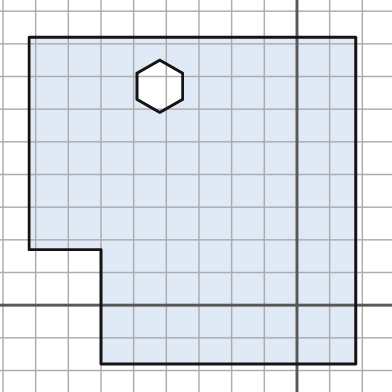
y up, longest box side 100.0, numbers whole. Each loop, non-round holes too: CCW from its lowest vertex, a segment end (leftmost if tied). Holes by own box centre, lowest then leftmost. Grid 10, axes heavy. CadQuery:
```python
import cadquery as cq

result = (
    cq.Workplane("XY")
    .moveTo(-60.0, -18.0)
    .lineTo(18.0, -18.0)
    .lineTo(18.0, 82.0)
    .lineTo(-82.0, 82.0)
    .lineTo(-82.0, 17.0)
    .lineTo(-60.0, 17.0)
    .close()
    .moveTo(-42.0, 59.0)
    .lineTo(-35.0, 63.0)
    .lineTo(-35.0, 71.0)
    .lineTo(-42.0, 75.0)
    .lineTo(-49.0, 71.0)
    .lineTo(-49.0, 63.0)
    .close()
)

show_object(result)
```